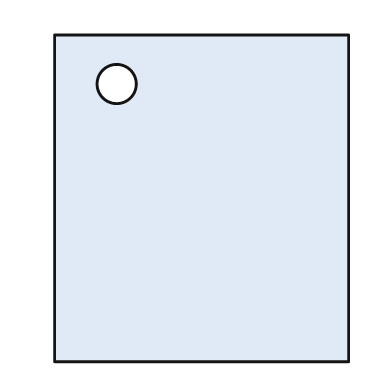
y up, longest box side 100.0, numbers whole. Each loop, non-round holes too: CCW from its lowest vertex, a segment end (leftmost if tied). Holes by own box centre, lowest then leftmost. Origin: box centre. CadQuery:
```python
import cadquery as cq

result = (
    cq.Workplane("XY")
    .moveTo(-45.0, -50.0)
    .lineTo(45.0, -50.0)
    .lineTo(45.0, 50.0)
    .lineTo(-45.0, 50.0)
    .close()
    .moveTo(-26.0, 35.0)
    .circle(6.0)
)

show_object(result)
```